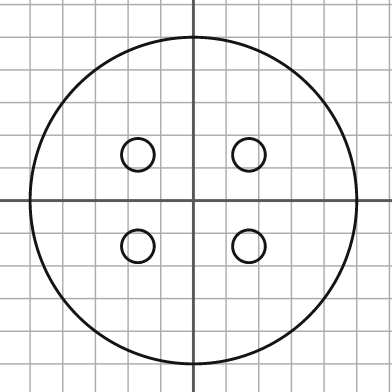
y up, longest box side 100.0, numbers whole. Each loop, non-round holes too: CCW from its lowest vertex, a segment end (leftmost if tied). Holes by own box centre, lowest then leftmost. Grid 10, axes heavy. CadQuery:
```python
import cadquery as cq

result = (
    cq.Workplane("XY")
    .moveTo(0.0, 0.0)
    .circle(50.0)
    .moveTo(-17.0, -14.0)
    .circle(5.0)
    .moveTo(17.0, -14.0)
    .circle(5.0)
    .moveTo(-17.0, 14.0)
    .circle(5.0)
    .moveTo(17.0, 14.0)
    .circle(5.0)
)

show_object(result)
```